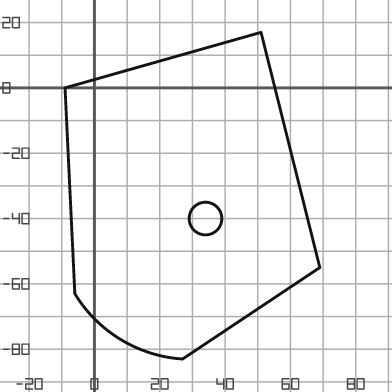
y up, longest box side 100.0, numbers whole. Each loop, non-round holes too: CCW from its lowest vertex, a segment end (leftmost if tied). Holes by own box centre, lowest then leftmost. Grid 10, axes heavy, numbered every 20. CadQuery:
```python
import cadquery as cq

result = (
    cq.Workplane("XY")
    .moveTo(27.0, -83.0)
    .lineTo(69.0, -55.0)
    .lineTo(51.0, 17.0)
    .lineTo(-9.0, 0.0)
    .lineTo(-6.0, -63.0)
    .threePointArc((8.0, -77.0), (27.0, -83.0))
    .close()
    .moveTo(34.0, -40.0)
    .circle(5.0)
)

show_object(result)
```